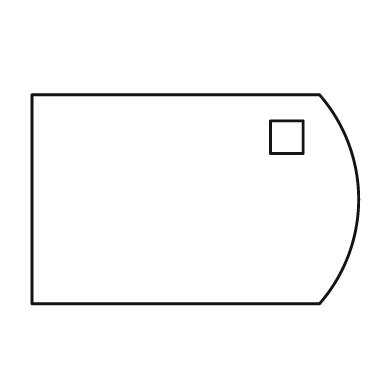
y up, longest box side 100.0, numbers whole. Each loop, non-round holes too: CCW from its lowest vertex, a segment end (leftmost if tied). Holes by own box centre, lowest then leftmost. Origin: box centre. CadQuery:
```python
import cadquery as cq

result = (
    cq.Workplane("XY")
    .moveTo(-50.0, -32.0)
    .lineTo(38.0, -32.0)
    .threePointArc((50.0, 0.0), (38.0, 32.0))
    .lineTo(-50.0, 32.0)
    .close()
    .moveTo(23.0, 14.0)
    .lineTo(33.0, 14.0)
    .lineTo(33.0, 24.0)
    .lineTo(23.0, 24.0)
    .close()
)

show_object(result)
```